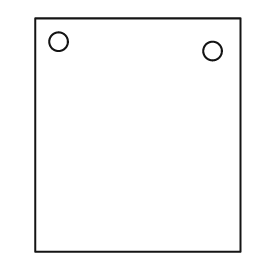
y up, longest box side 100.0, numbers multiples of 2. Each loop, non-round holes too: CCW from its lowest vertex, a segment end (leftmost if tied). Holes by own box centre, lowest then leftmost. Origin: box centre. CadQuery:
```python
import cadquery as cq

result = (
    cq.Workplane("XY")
    .moveTo(-44.0, -50.0)
    .lineTo(44.0, -50.0)
    .lineTo(44.0, 50.0)
    .lineTo(-44.0, 50.0)
    .close()
    .moveTo(32.0, 36.0)
    .circle(4.0)
    .moveTo(-34.0, 40.0)
    .circle(4.0)
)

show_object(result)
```